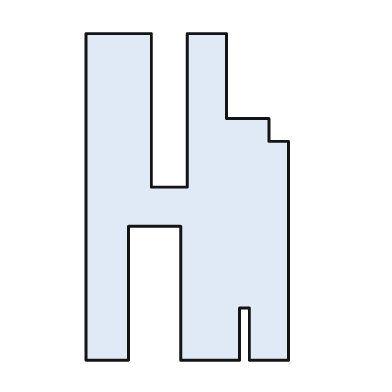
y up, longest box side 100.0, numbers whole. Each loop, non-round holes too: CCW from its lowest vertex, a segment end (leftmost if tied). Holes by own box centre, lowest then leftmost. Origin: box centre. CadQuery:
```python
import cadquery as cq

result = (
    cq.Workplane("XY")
    .moveTo(-31.0, -50.0)
    .lineTo(-18.0, -50.0)
    .lineTo(-18.0, -9.0)
    .lineTo(-2.0, -9.0)
    .lineTo(-2.0, -50.0)
    .lineTo(16.0, -50.0)
    .lineTo(16.0, -34.0)
    .lineTo(19.0, -34.0)
    .lineTo(19.0, -50.0)
    .lineTo(31.0, -50.0)
    .lineTo(31.0, 17.0)
    .lineTo(25.0, 17.0)
    .lineTo(25.0, 24.0)
    .lineTo(12.0, 24.0)
    .lineTo(12.0, 50.0)
    .lineTo(0.0, 50.0)
    .lineTo(0.0, 3.0)
    .lineTo(-11.0, 3.0)
    .lineTo(-11.0, 50.0)
    .lineTo(-31.0, 50.0)
    .close()
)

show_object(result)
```